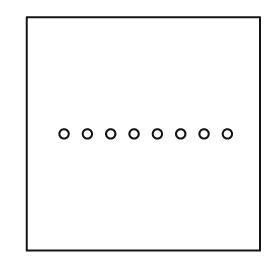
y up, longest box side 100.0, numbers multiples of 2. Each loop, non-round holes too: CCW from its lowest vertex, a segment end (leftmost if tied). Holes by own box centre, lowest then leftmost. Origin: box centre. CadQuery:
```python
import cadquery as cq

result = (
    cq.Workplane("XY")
    .moveTo(-50.0, -50.0)
    .lineTo(50.0, -50.0)
    .lineTo(50.0, 50.0)
    .lineTo(-50.0, 50.0)
    .close()
    .moveTo(-34.0, 0.0)
    .circle(2.0)
    .moveTo(-24.0, 0.0)
    .circle(2.0)
    .moveTo(-14.0, 0.0)
    .circle(2.0)
    .moveTo(-4.0, 0.0)
    .circle(2.0)
    .moveTo(6.0, 0.0)
    .circle(2.0)
    .moveTo(16.0, 0.0)
    .circle(2.0)
    .moveTo(26.0, 0.0)
    .circle(2.0)
    .moveTo(36.0, 0.0)
    .circle(2.0)
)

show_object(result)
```